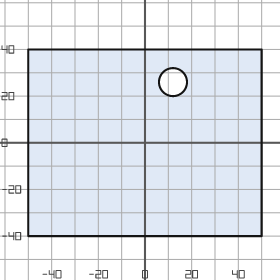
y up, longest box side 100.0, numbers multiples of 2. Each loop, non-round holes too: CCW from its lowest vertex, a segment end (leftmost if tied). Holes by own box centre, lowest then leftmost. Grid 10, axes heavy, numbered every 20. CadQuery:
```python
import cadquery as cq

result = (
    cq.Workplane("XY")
    .moveTo(-50.0, -40.0)
    .lineTo(50.0, -40.0)
    .lineTo(50.0, 40.0)
    .lineTo(-50.0, 40.0)
    .close()
    .moveTo(12.0, 26.0)
    .circle(6.0)
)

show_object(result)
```